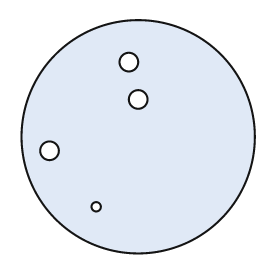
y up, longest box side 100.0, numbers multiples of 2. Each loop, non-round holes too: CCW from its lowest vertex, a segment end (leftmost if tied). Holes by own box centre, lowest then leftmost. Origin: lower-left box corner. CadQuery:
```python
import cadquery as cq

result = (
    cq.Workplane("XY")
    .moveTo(50.0, 50.0)
    .circle(50.0)
    .moveTo(32.0, 20.0)
    .circle(2.0)
    .moveTo(12.0, 44.0)
    .circle(4.0)
    .moveTo(50.0, 66.0)
    .circle(4.0)
    .moveTo(46.0, 82.0)
    .circle(4.0)
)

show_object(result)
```